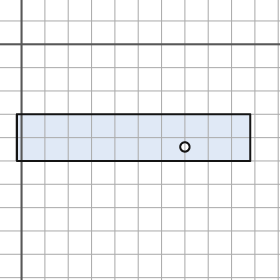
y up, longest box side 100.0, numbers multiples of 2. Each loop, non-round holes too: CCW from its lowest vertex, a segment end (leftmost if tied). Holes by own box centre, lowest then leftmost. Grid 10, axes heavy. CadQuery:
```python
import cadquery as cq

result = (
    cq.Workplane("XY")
    .moveTo(-2.0, -50.0)
    .lineTo(98.0, -50.0)
    .lineTo(98.0, -30.0)
    .lineTo(-2.0, -30.0)
    .close()
    .moveTo(70.0, -44.0)
    .circle(2.0)
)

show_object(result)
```